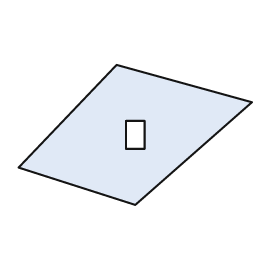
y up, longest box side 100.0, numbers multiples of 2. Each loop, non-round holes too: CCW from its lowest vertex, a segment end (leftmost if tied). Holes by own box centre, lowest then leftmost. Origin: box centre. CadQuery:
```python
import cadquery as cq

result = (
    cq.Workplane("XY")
    .moveTo(0.0, -30.0)
    .lineTo(50.0, 14.0)
    .lineTo(-8.0, 30.0)
    .lineTo(-50.0, -14.0)
    .close()
    .moveTo(-4.0, -6.0)
    .lineTo(4.0, -6.0)
    .lineTo(4.0, 6.0)
    .lineTo(-4.0, 6.0)
    .close()
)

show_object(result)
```